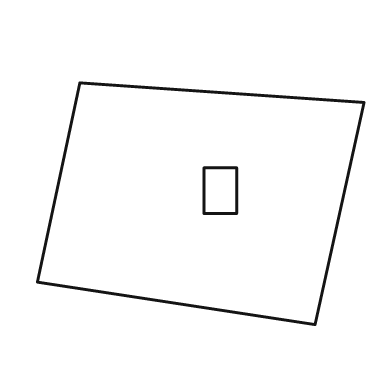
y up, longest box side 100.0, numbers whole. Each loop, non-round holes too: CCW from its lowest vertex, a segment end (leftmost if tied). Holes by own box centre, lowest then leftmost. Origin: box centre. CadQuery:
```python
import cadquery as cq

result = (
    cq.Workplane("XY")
    .moveTo(35.0, -37.0)
    .lineTo(50.0, 31.0)
    .lineTo(-37.0, 37.0)
    .lineTo(-50.0, -24.0)
    .close()
    .moveTo(1.0, -3.0)
    .lineTo(11.0, -3.0)
    .lineTo(11.0, 11.0)
    .lineTo(1.0, 11.0)
    .close()
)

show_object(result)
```